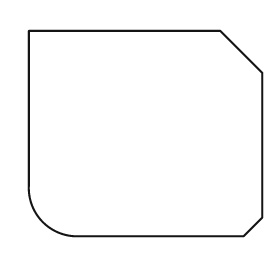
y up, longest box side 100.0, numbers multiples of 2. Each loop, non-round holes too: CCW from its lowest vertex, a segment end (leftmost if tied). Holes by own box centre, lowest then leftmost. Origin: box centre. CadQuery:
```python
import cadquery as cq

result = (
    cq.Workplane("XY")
    .moveTo(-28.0, -44.0)
    .lineTo(42.0, -44.0)
    .lineTo(50.0, -36.0)
    .lineTo(50.0, 26.0)
    .lineTo(32.0, 44.0)
    .lineTo(-50.0, 44.0)
    .lineTo(-50.0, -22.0)
    .threePointArc((-44.0, -38.0), (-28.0, -44.0))
    .close()
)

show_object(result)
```